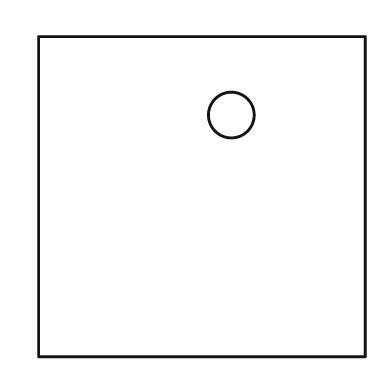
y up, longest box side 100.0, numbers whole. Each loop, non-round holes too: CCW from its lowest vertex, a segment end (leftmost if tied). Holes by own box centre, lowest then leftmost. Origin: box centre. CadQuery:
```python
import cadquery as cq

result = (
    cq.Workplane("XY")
    .moveTo(-50.0, -49.0)
    .lineTo(50.0, -49.0)
    .lineTo(50.0, 49.0)
    .lineTo(-50.0, 49.0)
    .close()
    .moveTo(9.0, 25.0)
    .circle(7.0)
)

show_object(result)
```